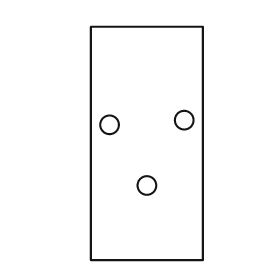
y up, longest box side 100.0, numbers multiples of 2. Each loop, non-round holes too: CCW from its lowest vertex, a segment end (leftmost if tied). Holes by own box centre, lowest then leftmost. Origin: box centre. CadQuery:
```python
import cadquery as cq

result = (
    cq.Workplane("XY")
    .moveTo(-24.0, -50.0)
    .lineTo(24.0, -50.0)
    .lineTo(24.0, 50.0)
    .lineTo(-24.0, 50.0)
    .close()
    .moveTo(0.0, -18.0)
    .circle(4.0)
    .moveTo(-16.0, 8.0)
    .circle(4.0)
    .moveTo(16.0, 10.0)
    .circle(4.0)
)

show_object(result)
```